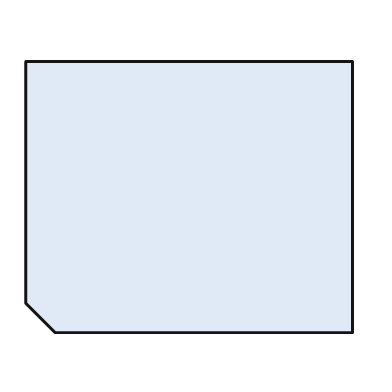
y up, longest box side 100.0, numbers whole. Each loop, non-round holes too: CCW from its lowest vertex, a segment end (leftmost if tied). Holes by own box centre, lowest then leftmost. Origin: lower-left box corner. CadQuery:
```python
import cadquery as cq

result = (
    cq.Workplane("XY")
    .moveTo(9.0, 0.0)
    .lineTo(100.0, 0.0)
    .lineTo(100.0, 83.0)
    .lineTo(0.0, 83.0)
    .lineTo(0.0, 9.0)
    .close()
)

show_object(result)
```